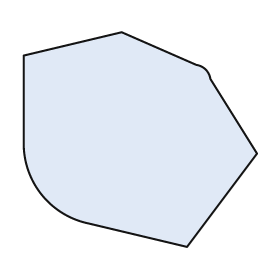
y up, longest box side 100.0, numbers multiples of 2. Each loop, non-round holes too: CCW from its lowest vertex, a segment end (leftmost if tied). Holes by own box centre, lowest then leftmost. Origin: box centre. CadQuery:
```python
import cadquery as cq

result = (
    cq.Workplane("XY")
    .moveTo(20.0, -46.0)
    .lineTo(50.0, -6.0)
    .lineTo(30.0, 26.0)
    .threePointArc((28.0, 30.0), (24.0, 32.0))
    .lineTo(-8.0, 46.0)
    .lineTo(-50.0, 36.0)
    .lineTo(-50.0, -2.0)
    .threePointArc((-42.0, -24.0), (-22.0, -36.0))
    .close()
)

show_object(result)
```